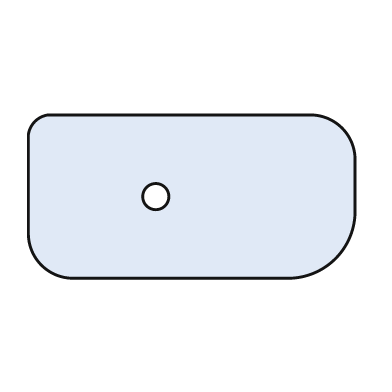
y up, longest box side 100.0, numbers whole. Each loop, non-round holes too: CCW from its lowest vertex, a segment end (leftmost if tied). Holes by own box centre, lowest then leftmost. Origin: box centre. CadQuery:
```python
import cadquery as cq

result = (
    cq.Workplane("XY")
    .moveTo(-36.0, -25.0)
    .lineTo(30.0, -25.0)
    .threePointArc((44.0, -19.0), (50.0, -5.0))
    .lineTo(50.0, 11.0)
    .threePointArc((46.0, 21.0), (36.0, 25.0))
    .lineTo(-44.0, 25.0)
    .threePointArc((-48.0, 23.0), (-50.0, 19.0))
    .lineTo(-50.0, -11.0)
    .threePointArc((-46.0, -21.0), (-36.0, -25.0))
    .close()
    .moveTo(-11.0, 0.0)
    .circle(4.0)
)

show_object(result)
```